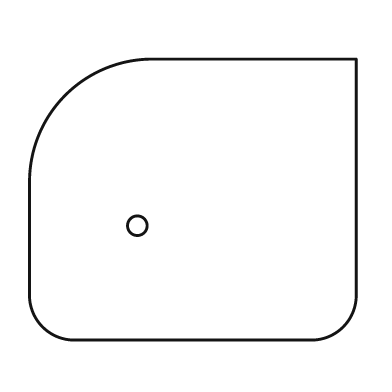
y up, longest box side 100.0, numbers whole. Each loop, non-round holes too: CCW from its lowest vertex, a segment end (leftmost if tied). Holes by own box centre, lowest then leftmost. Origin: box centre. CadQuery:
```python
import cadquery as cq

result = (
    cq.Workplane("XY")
    .moveTo(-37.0, -43.0)
    .lineTo(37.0, -43.0)
    .threePointArc((46.0, -39.0), (50.0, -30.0))
    .lineTo(50.0, 43.0)
    .lineTo(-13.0, 43.0)
    .threePointArc((-39.0, 32.0), (-50.0, 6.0))
    .lineTo(-50.0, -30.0)
    .threePointArc((-46.0, -39.0), (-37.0, -43.0))
    .close()
    .moveTo(-17.0, -8.0)
    .circle(3.0)
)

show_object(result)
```